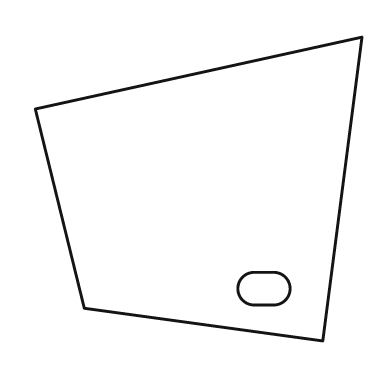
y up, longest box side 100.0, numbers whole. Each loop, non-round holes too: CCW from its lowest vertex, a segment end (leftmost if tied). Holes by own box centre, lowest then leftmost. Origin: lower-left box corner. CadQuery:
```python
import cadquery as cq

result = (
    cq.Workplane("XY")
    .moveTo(88.0, 0.0)
    .lineTo(100.0, 93.0)
    .lineTo(0.0, 71.0)
    .lineTo(15.0, 10.0)
    .close()
    .moveTo(67.0, 11.0)
    .lineTo(73.0, 11.0)
    .threePointArc((78.0, 16.0), (73.0, 21.0))
    .lineTo(67.0, 21.0)
    .threePointArc((62.0, 16.0), (67.0, 11.0))
    .close()
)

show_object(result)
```